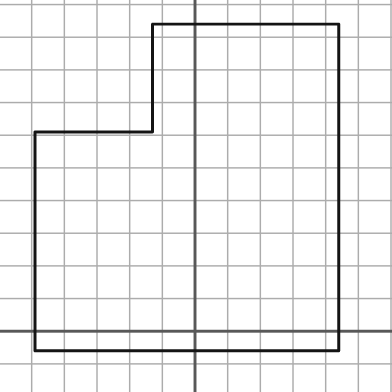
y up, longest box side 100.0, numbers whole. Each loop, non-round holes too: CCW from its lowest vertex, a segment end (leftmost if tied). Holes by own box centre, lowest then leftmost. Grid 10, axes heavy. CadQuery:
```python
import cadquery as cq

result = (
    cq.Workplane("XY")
    .moveTo(-49.0, -6.0)
    .lineTo(44.0, -6.0)
    .lineTo(44.0, 94.0)
    .lineTo(-13.0, 94.0)
    .lineTo(-13.0, 61.0)
    .lineTo(-49.0, 61.0)
    .close()
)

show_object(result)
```